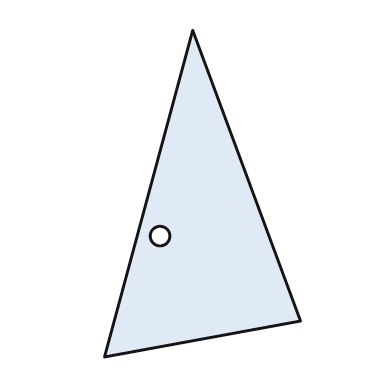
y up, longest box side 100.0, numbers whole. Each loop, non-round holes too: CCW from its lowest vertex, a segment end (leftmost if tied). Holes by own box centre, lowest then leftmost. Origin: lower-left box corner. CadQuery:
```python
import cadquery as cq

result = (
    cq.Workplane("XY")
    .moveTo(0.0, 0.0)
    .lineTo(60.0, 11.0)
    .lineTo(27.0, 100.0)
    .close()
    .moveTo(17.0, 37.0)
    .circle(3.0)
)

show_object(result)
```